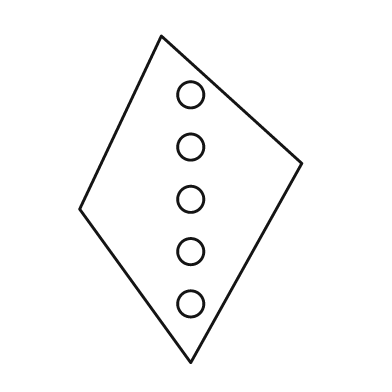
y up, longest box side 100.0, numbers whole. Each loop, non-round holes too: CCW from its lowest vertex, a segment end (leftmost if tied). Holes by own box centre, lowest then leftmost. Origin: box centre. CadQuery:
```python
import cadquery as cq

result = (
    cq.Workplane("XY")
    .moveTo(0.0, -50.0)
    .lineTo(34.0, 11.0)
    .lineTo(-9.0, 50.0)
    .lineTo(-34.0, -3.0)
    .close()
    .moveTo(0.0, -32.0)
    .circle(4.0)
    .moveTo(0.0, -16.0)
    .circle(4.0)
    .moveTo(0.0, 0.0)
    .circle(4.0)
    .moveTo(0.0, 16.0)
    .circle(4.0)
    .moveTo(0.0, 32.0)
    .circle(4.0)
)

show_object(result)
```